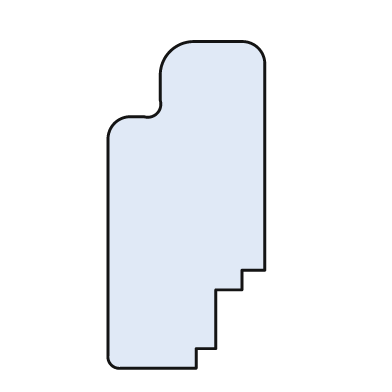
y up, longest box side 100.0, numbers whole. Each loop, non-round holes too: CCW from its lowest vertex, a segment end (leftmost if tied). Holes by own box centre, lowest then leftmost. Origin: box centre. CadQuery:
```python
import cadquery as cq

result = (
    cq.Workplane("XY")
    .moveTo(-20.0, -50.0)
    .lineTo(3.0, -50.0)
    .lineTo(3.0, -44.0)
    .lineTo(9.0, -44.0)
    .lineTo(9.0, -26.0)
    .lineTo(17.0, -26.0)
    .lineTo(17.0, -20.0)
    .lineTo(24.0, -20.0)
    .lineTo(24.0, 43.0)
    .threePointArc((22.0, 48.0), (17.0, 50.0))
    .lineTo(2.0, 50.0)
    .threePointArc((-5.0, 47.0), (-8.0, 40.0))
    .lineTo(-8.0, 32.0)
    .threePointArc((-9.0, 28.0), (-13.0, 27.0))
    .lineTo(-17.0, 27.0)
    .threePointArc((-22.0, 25.0), (-24.0, 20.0))
    .lineTo(-24.0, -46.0)
    .threePointArc((-23.0, -49.0), (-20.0, -50.0))
    .close()
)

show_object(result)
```